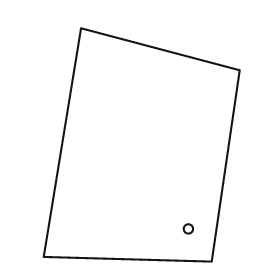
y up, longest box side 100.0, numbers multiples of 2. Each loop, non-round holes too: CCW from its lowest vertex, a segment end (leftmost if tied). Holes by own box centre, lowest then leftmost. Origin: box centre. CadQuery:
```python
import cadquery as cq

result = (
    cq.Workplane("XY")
    .moveTo(30.0, -50.0)
    .lineTo(42.0, 32.0)
    .lineTo(-26.0, 50.0)
    .lineTo(-42.0, -48.0)
    .close()
    .moveTo(20.0, -36.0)
    .circle(2.0)
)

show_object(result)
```